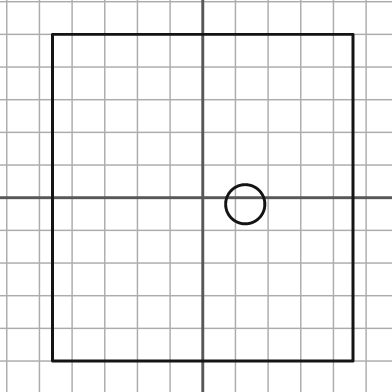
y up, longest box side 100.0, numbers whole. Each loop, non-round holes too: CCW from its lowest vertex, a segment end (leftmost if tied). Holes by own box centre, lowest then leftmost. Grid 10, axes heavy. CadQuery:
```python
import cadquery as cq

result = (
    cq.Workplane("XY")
    .moveTo(-46.0, -50.0)
    .lineTo(46.0, -50.0)
    .lineTo(46.0, 50.0)
    .lineTo(-46.0, 50.0)
    .close()
    .moveTo(13.0, -2.0)
    .circle(6.0)
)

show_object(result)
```